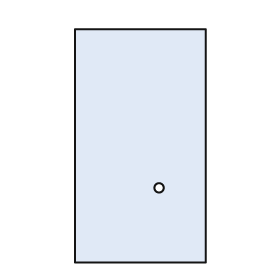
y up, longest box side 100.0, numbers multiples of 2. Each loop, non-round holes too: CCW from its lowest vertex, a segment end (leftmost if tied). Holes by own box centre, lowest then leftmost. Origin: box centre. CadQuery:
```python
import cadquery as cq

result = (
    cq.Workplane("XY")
    .moveTo(-28.0, -50.0)
    .lineTo(28.0, -50.0)
    .lineTo(28.0, 50.0)
    .lineTo(-28.0, 50.0)
    .close()
    .moveTo(8.0, -18.0)
    .circle(2.0)
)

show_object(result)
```